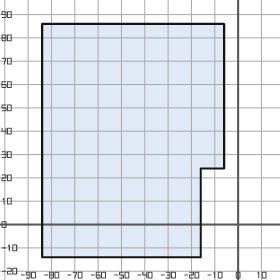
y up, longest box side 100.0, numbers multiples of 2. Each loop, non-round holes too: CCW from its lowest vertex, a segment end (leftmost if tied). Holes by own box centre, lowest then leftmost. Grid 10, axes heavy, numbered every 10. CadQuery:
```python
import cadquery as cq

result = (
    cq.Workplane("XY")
    .moveTo(-84.0, -14.0)
    .lineTo(-16.0, -14.0)
    .lineTo(-16.0, 24.0)
    .lineTo(-6.0, 24.0)
    .lineTo(-6.0, 86.0)
    .lineTo(-84.0, 86.0)
    .close()
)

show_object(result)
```